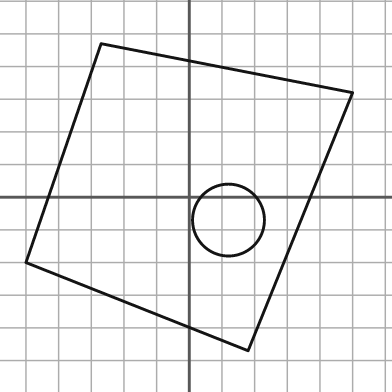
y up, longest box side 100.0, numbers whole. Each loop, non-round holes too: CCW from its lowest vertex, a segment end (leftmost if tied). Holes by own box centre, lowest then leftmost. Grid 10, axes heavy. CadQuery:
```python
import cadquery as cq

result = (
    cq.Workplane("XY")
    .moveTo(18.0, -47.0)
    .lineTo(50.0, 32.0)
    .lineTo(-27.0, 47.0)
    .lineTo(-50.0, -20.0)
    .close()
    .moveTo(12.0, -7.0)
    .circle(11.0)
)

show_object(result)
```